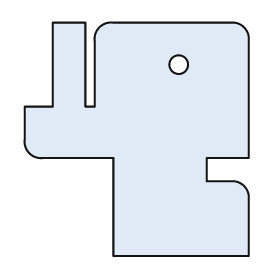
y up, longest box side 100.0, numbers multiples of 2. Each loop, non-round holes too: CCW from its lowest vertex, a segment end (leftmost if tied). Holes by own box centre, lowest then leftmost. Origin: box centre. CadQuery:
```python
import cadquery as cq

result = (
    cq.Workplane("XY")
    .moveTo(-10.0, -50.0)
    .lineTo(48.0, -50.0)
    .lineTo(48.0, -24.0)
    .threePointArc((46.0, -20.0), (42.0, -18.0))
    .lineTo(30.0, -18.0)
    .lineTo(30.0, -8.0)
    .lineTo(48.0, -8.0)
    .lineTo(48.0, 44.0)
    .threePointArc((46.0, 48.0), (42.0, 50.0))
    .lineTo(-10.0, 50.0)
    .threePointArc((-16.0, 48.0), (-18.0, 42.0))
    .lineTo(-18.0, 14.0)
    .lineTo(-22.0, 14.0)
    .lineTo(-22.0, 50.0)
    .lineTo(-36.0, 50.0)
    .lineTo(-36.0, 14.0)
    .lineTo(-48.0, 14.0)
    .lineTo(-48.0, 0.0)
    .threePointArc((-46.0, -6.0), (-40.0, -8.0))
    .lineTo(-10.0, -8.0)
    .close()
    .moveTo(18.0, 32.0)
    .circle(4.0)
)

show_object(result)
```